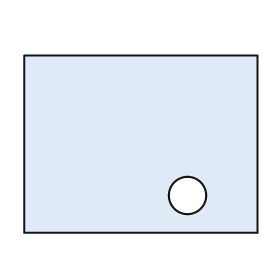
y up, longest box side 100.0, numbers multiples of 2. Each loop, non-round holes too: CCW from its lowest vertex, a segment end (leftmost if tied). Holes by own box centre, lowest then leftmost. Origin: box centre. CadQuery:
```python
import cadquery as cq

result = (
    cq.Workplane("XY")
    .moveTo(-50.0, -38.0)
    .lineTo(50.0, -38.0)
    .lineTo(50.0, 38.0)
    .lineTo(-50.0, 38.0)
    .close()
    .moveTo(20.0, -22.0)
    .circle(8.0)
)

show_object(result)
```